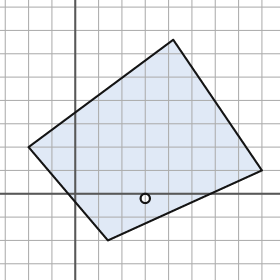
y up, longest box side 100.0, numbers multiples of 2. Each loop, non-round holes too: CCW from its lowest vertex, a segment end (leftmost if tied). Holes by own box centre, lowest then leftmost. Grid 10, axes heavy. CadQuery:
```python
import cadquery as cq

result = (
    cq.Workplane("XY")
    .moveTo(14.0, -20.0)
    .lineTo(80.0, 10.0)
    .lineTo(42.0, 66.0)
    .lineTo(-20.0, 20.0)
    .close()
    .moveTo(30.0, -2.0)
    .circle(2.0)
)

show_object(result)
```